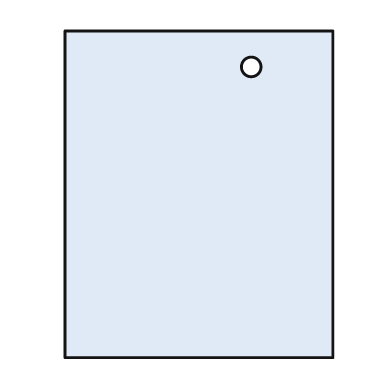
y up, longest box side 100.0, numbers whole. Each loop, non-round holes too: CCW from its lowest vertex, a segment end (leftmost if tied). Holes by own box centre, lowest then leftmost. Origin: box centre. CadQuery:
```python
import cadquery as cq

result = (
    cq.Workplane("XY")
    .moveTo(-41.0, -50.0)
    .lineTo(41.0, -50.0)
    .lineTo(41.0, 50.0)
    .lineTo(-41.0, 50.0)
    .close()
    .moveTo(16.0, 39.0)
    .circle(3.0)
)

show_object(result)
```